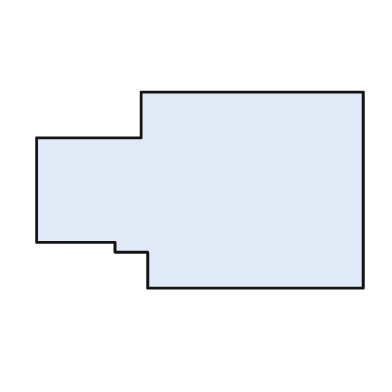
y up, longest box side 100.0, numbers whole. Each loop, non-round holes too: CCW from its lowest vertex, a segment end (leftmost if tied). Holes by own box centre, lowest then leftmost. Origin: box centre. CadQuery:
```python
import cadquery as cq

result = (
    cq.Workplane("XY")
    .moveTo(-16.0, -30.0)
    .lineTo(50.0, -30.0)
    .lineTo(50.0, 30.0)
    .lineTo(-18.0, 30.0)
    .lineTo(-18.0, 16.0)
    .lineTo(-50.0, 16.0)
    .lineTo(-50.0, -16.0)
    .lineTo(-26.0, -16.0)
    .lineTo(-26.0, -19.0)
    .lineTo(-16.0, -19.0)
    .close()
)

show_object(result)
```